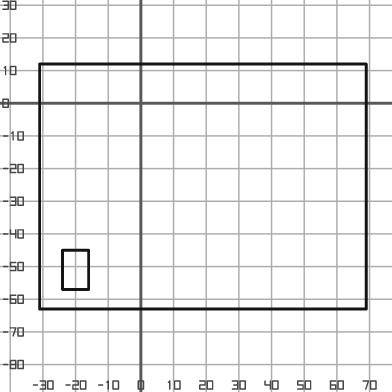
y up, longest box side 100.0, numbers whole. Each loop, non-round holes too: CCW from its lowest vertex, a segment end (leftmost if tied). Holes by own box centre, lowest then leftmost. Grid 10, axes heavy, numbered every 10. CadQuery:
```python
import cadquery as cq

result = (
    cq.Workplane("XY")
    .moveTo(-31.0, -63.0)
    .lineTo(69.0, -63.0)
    .lineTo(69.0, 12.0)
    .lineTo(-31.0, 12.0)
    .close()
    .moveTo(-24.0, -57.0)
    .lineTo(-16.0, -57.0)
    .lineTo(-16.0, -45.0)
    .lineTo(-24.0, -45.0)
    .close()
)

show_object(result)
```